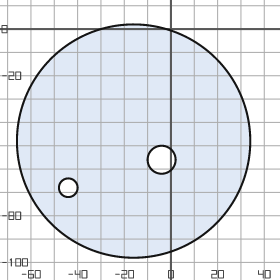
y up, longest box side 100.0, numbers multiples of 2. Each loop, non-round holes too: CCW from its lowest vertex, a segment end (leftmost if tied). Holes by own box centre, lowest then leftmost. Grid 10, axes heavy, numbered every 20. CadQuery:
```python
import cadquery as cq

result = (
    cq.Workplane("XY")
    .moveTo(-16.0, -48.0)
    .circle(50.0)
    .moveTo(-44.0, -68.0)
    .circle(4.0)
    .moveTo(-4.0, -56.0)
    .circle(6.0)
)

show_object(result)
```